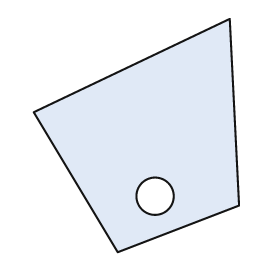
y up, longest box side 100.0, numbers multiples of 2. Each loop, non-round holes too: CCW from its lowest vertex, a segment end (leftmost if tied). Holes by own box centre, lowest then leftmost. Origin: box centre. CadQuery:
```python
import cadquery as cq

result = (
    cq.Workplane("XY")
    .moveTo(-8.0, -50.0)
    .lineTo(44.0, -30.0)
    .lineTo(40.0, 50.0)
    .lineTo(-44.0, 10.0)
    .close()
    .moveTo(8.0, -26.0)
    .circle(8.0)
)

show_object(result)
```